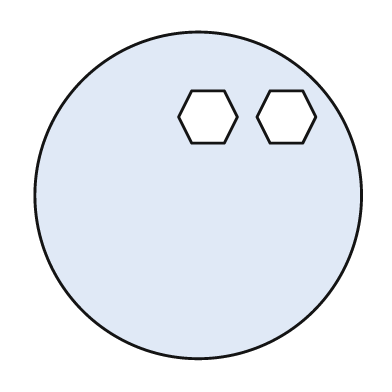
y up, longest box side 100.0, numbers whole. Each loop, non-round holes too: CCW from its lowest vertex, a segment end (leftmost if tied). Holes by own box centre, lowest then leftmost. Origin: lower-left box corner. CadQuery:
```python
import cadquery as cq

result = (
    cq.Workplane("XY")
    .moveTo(50.0, 50.0)
    .circle(50.0)
    .moveTo(48.0, 66.0)
    .lineTo(58.0, 66.0)
    .lineTo(62.0, 74.0)
    .lineTo(58.0, 82.0)
    .lineTo(48.0, 82.0)
    .lineTo(44.0, 74.0)
    .close()
    .moveTo(72.0, 66.0)
    .lineTo(82.0, 66.0)
    .lineTo(86.0, 74.0)
    .lineTo(82.0, 82.0)
    .lineTo(72.0, 82.0)
    .lineTo(68.0, 74.0)
    .close()
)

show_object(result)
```